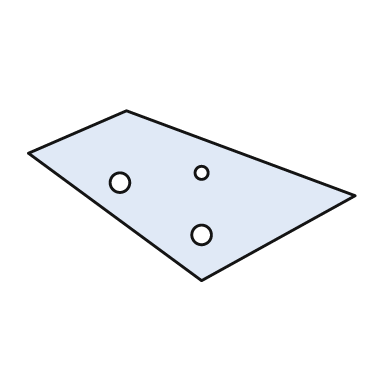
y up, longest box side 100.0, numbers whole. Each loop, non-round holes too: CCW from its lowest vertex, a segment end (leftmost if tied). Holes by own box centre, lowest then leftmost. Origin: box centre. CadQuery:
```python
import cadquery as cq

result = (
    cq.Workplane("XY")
    .moveTo(3.0, -26.0)
    .lineTo(50.0, 0.0)
    .lineTo(-20.0, 26.0)
    .lineTo(-50.0, 13.0)
    .close()
    .moveTo(3.0, -12.0)
    .circle(3.0)
    .moveTo(-22.0, 4.0)
    .circle(3.0)
    .moveTo(3.0, 7.0)
    .circle(2.0)
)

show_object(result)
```